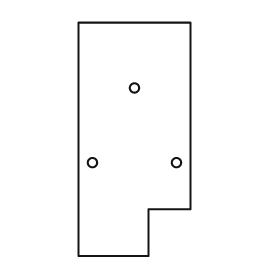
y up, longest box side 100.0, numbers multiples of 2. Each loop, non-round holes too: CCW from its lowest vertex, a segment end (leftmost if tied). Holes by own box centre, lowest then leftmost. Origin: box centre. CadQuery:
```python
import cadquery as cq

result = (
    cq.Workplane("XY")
    .moveTo(-24.0, -50.0)
    .lineTo(6.0, -50.0)
    .lineTo(6.0, -30.0)
    .lineTo(24.0, -30.0)
    .lineTo(24.0, 50.0)
    .lineTo(-24.0, 50.0)
    .close()
    .moveTo(-18.0, -10.0)
    .circle(2.0)
    .moveTo(18.0, -10.0)
    .circle(2.0)
    .moveTo(0.0, 22.0)
    .circle(2.0)
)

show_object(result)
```